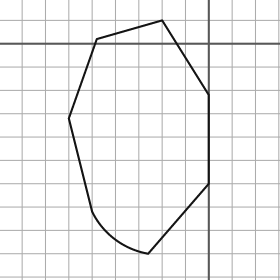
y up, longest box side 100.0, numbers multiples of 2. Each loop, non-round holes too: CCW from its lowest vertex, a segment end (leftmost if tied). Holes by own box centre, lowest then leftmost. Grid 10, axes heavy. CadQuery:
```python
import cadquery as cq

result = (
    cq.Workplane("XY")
    .moveTo(-26.0, -90.0)
    .lineTo(0.0, -60.0)
    .lineTo(0.0, -22.0)
    .lineTo(-20.0, 10.0)
    .lineTo(-48.0, 2.0)
    .lineTo(-60.0, -32.0)
    .lineTo(-50.0, -72.0)
    .threePointArc((-40.0, -84.0), (-26.0, -90.0))
    .close()
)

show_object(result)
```